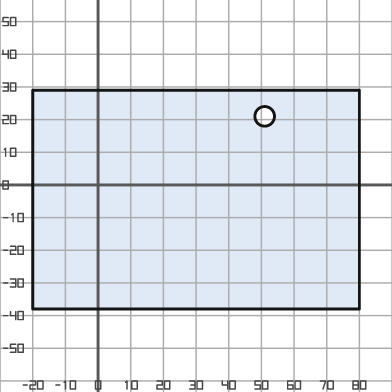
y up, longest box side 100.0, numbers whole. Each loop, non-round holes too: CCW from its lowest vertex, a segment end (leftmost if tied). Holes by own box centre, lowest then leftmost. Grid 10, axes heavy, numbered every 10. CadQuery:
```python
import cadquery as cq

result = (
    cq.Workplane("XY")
    .moveTo(-20.0, -38.0)
    .lineTo(80.0, -38.0)
    .lineTo(80.0, 29.0)
    .lineTo(-20.0, 29.0)
    .close()
    .moveTo(51.0, 21.0)
    .circle(3.0)
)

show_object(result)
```